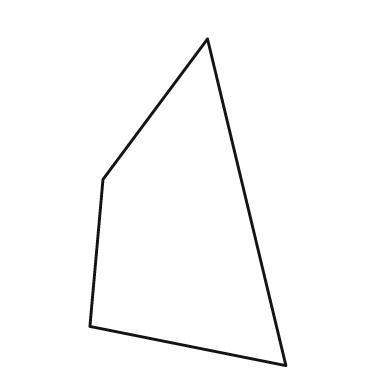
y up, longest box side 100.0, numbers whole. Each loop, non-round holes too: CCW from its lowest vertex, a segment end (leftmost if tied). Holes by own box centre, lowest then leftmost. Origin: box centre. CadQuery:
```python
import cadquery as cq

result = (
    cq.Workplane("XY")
    .moveTo(30.0, -50.0)
    .lineTo(6.0, 50.0)
    .lineTo(-26.0, 7.0)
    .lineTo(-30.0, -38.0)
    .close()
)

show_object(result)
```